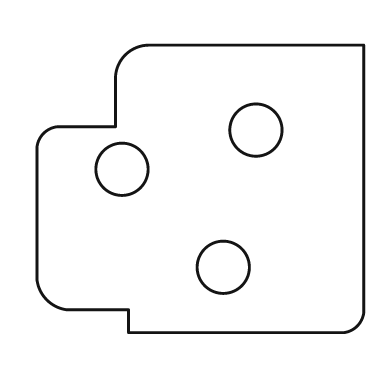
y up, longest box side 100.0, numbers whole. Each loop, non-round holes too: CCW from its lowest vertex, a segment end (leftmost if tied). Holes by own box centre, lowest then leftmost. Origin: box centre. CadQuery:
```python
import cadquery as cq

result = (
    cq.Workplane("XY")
    .moveTo(-22.0, -44.0)
    .lineTo(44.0, -44.0)
    .threePointArc((48.0, -42.0), (50.0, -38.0))
    .lineTo(50.0, 44.0)
    .lineTo(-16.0, 44.0)
    .threePointArc((-23.0, 41.0), (-26.0, 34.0))
    .lineTo(-26.0, 19.0)
    .lineTo(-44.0, 19.0)
    .threePointArc((-48.0, 17.0), (-50.0, 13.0))
    .lineTo(-50.0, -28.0)
    .threePointArc((-47.0, -34.0), (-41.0, -37.0))
    .lineTo(-22.0, -37.0)
    .close()
    .moveTo(7.0, -24.0)
    .circle(8.0)
    .moveTo(-24.0, 6.0)
    .circle(8.0)
    .moveTo(17.0, 18.0)
    .circle(8.0)
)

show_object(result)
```